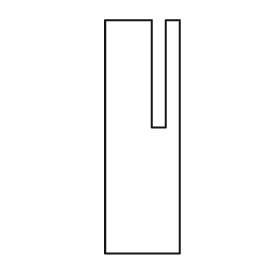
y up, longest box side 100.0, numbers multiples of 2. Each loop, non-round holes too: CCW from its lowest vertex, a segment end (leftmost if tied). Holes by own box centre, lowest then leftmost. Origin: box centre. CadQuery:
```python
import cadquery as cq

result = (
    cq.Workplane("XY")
    .moveTo(-16.0, -50.0)
    .lineTo(16.0, -50.0)
    .lineTo(16.0, 50.0)
    .lineTo(10.0, 50.0)
    .lineTo(10.0, 4.0)
    .lineTo(4.0, 4.0)
    .lineTo(4.0, 50.0)
    .lineTo(-16.0, 50.0)
    .close()
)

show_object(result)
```